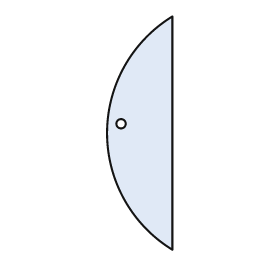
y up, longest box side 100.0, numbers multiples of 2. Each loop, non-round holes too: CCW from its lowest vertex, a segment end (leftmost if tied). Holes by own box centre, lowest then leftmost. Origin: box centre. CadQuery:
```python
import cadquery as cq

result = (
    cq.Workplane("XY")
    .moveTo(14.0, -50.0)
    .lineTo(14.0, 50.0)
    .threePointArc((-14.0, 0.0), (14.0, -50.0))
    .close()
    .moveTo(-8.0, 4.0)
    .circle(2.0)
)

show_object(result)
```